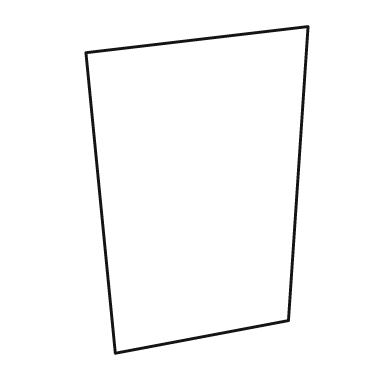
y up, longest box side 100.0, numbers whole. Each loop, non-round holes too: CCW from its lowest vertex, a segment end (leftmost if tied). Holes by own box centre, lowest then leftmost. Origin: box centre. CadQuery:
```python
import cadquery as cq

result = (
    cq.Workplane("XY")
    .moveTo(-25.0, -50.0)
    .lineTo(28.0, -40.0)
    .lineTo(34.0, 50.0)
    .lineTo(-34.0, 42.0)
    .close()
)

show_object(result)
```